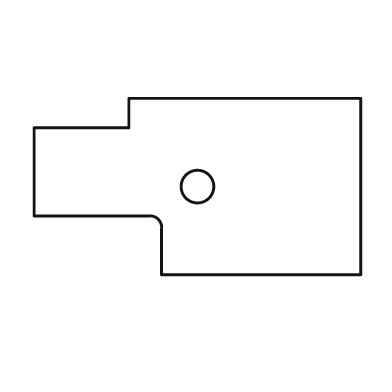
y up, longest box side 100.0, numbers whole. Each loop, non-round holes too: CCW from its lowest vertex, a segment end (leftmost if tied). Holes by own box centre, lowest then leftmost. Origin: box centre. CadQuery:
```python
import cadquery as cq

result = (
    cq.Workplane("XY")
    .moveTo(-11.0, -27.0)
    .lineTo(50.0, -27.0)
    .lineTo(50.0, 27.0)
    .lineTo(-21.0, 27.0)
    .lineTo(-21.0, 18.0)
    .lineTo(-50.0, 18.0)
    .lineTo(-50.0, -9.0)
    .lineTo(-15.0, -9.0)
    .threePointArc((-12.0, -10.0), (-11.0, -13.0))
    .close()
    .moveTo(0.0, 0.0)
    .circle(5.0)
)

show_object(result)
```